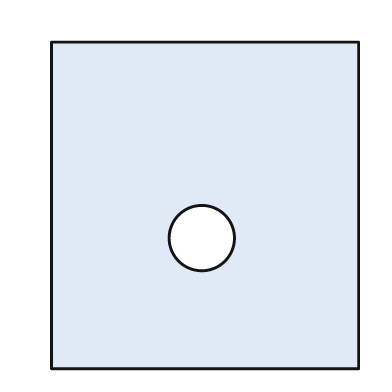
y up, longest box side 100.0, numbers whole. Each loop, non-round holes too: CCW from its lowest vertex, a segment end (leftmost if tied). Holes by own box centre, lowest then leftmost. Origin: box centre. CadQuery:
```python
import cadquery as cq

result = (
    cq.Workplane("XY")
    .moveTo(-47.0, -50.0)
    .lineTo(47.0, -50.0)
    .lineTo(47.0, 50.0)
    .lineTo(-47.0, 50.0)
    .close()
    .moveTo(-1.0, -10.0)
    .circle(10.0)
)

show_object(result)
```